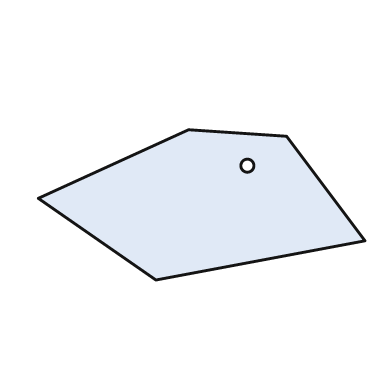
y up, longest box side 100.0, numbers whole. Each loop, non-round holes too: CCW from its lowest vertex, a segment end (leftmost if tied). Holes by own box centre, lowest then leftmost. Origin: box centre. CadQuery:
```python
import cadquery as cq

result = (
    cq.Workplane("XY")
    .moveTo(-14.0, -23.0)
    .lineTo(50.0, -11.0)
    .lineTo(26.0, 21.0)
    .lineTo(-4.0, 23.0)
    .lineTo(-50.0, 2.0)
    .close()
    .moveTo(14.0, 12.0)
    .circle(2.0)
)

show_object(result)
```